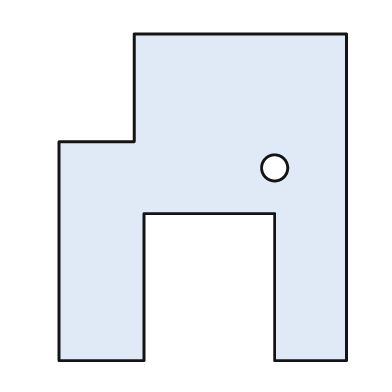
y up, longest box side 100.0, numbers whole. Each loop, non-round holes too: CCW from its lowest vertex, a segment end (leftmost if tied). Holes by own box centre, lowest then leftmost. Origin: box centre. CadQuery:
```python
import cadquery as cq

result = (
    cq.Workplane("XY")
    .moveTo(-44.0, -50.0)
    .lineTo(-18.0, -50.0)
    .lineTo(-18.0, -5.0)
    .lineTo(22.0, -5.0)
    .lineTo(22.0, -50.0)
    .lineTo(44.0, -50.0)
    .lineTo(44.0, 50.0)
    .lineTo(-21.0, 50.0)
    .lineTo(-21.0, 17.0)
    .lineTo(-44.0, 17.0)
    .close()
    .moveTo(22.0, 9.0)
    .circle(4.0)
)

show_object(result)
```